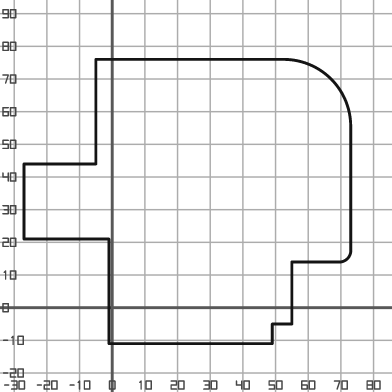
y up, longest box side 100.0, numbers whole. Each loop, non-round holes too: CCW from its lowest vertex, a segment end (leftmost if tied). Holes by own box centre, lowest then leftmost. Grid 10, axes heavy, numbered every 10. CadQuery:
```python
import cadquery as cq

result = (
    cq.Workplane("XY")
    .moveTo(-1.0, -11.0)
    .lineTo(49.0, -11.0)
    .lineTo(49.0, -5.0)
    .lineTo(55.0, -5.0)
    .lineTo(55.0, 14.0)
    .lineTo(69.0, 14.0)
    .threePointArc((72.0, 15.0), (73.0, 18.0))
    .lineTo(73.0, 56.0)
    .threePointArc((67.0, 70.0), (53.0, 76.0))
    .lineTo(-5.0, 76.0)
    .lineTo(-5.0, 44.0)
    .lineTo(-27.0, 44.0)
    .lineTo(-27.0, 21.0)
    .lineTo(-1.0, 21.0)
    .close()
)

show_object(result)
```